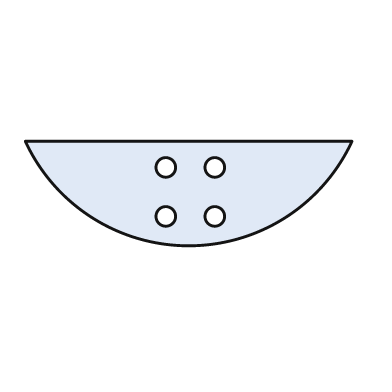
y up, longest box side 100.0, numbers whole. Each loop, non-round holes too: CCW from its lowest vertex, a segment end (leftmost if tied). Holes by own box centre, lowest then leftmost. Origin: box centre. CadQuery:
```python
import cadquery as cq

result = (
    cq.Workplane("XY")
    .moveTo(-50.0, 16.0)
    .threePointArc((0.0, -16.0), (50.0, 16.0))
    .close()
    .moveTo(-7.0, -7.0)
    .circle(3.0)
    .moveTo(8.0, -7.0)
    .circle(3.0)
    .moveTo(-7.0, 8.0)
    .circle(3.0)
    .moveTo(8.0, 8.0)
    .circle(3.0)
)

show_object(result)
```